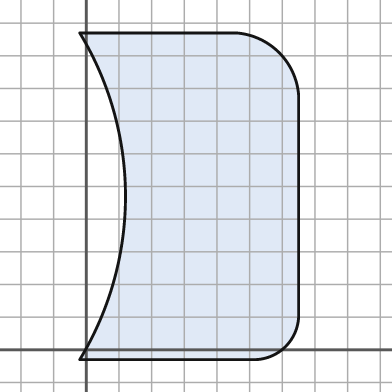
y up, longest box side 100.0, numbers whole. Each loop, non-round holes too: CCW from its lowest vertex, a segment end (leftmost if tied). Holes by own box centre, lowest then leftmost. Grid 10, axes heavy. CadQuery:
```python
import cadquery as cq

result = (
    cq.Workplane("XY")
    .moveTo(-2.0, -3.0)
    .lineTo(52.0, -3.0)
    .threePointArc((61.0, 1.0), (65.0, 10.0))
    .lineTo(65.0, 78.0)
    .threePointArc((59.0, 91.0), (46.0, 97.0))
    .lineTo(-2.0, 97.0)
    .threePointArc((12.0, 47.0), (-2.0, -3.0))
    .close()
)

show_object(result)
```